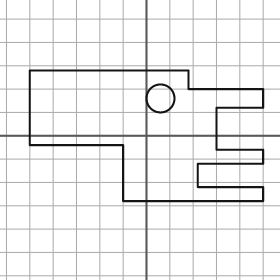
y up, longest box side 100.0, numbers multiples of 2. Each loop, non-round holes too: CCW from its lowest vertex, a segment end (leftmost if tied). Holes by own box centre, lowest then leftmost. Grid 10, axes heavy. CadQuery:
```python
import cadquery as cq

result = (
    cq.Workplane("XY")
    .moveTo(-10.0, -28.0)
    .lineTo(50.0, -28.0)
    .lineTo(50.0, -22.0)
    .lineTo(22.0, -22.0)
    .lineTo(22.0, -12.0)
    .lineTo(50.0, -12.0)
    .lineTo(50.0, -6.0)
    .lineTo(30.0, -6.0)
    .lineTo(30.0, 12.0)
    .lineTo(50.0, 12.0)
    .lineTo(50.0, 20.0)
    .lineTo(18.0, 20.0)
    .lineTo(18.0, 28.0)
    .lineTo(-50.0, 28.0)
    .lineTo(-50.0, -4.0)
    .lineTo(-10.0, -4.0)
    .close()
    .moveTo(6.0, 16.0)
    .circle(6.0)
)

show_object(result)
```